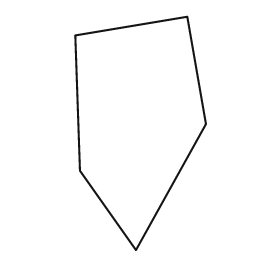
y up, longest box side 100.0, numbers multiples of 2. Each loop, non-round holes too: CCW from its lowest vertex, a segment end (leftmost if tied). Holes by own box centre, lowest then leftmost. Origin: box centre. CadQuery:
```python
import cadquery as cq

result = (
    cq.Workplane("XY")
    .moveTo(-2.0, -50.0)
    .lineTo(28.0, 4.0)
    .lineTo(20.0, 50.0)
    .lineTo(-28.0, 42.0)
    .lineTo(-26.0, -16.0)
    .close()
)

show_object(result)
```